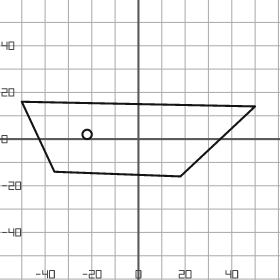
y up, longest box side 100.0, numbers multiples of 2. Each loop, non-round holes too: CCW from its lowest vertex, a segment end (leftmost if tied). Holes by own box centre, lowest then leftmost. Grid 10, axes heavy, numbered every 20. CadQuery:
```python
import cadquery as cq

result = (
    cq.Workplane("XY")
    .moveTo(18.0, -16.0)
    .lineTo(50.0, 14.0)
    .lineTo(-50.0, 16.0)
    .lineTo(-36.0, -14.0)
    .close()
    .moveTo(-22.0, 2.0)
    .circle(2.0)
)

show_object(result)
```